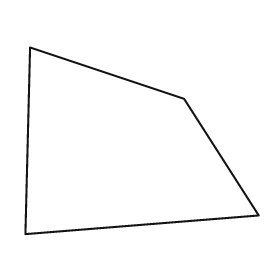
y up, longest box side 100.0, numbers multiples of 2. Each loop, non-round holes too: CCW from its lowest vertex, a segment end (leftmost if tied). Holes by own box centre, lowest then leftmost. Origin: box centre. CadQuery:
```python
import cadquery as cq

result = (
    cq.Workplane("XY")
    .moveTo(-50.0, -40.0)
    .lineTo(50.0, -32.0)
    .lineTo(18.0, 18.0)
    .lineTo(-48.0, 40.0)
    .close()
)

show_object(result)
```